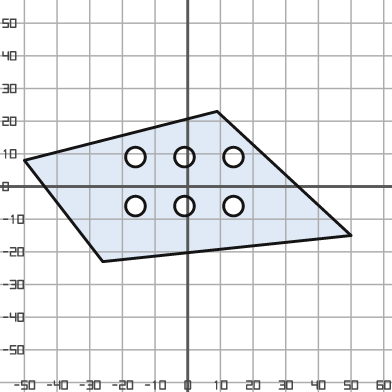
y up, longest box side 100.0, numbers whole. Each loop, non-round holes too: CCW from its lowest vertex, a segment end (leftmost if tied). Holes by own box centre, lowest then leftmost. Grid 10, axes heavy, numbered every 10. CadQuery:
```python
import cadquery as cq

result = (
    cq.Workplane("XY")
    .moveTo(-26.0, -23.0)
    .lineTo(50.0, -15.0)
    .lineTo(9.0, 23.0)
    .lineTo(-50.0, 8.0)
    .close()
    .moveTo(-16.0, -6.0)
    .circle(3.0)
    .moveTo(-1.0, -6.0)
    .circle(3.0)
    .moveTo(14.0, -6.0)
    .circle(3.0)
    .moveTo(-16.0, 9.0)
    .circle(3.0)
    .moveTo(-1.0, 9.0)
    .circle(3.0)
    .moveTo(14.0, 9.0)
    .circle(3.0)
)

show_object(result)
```